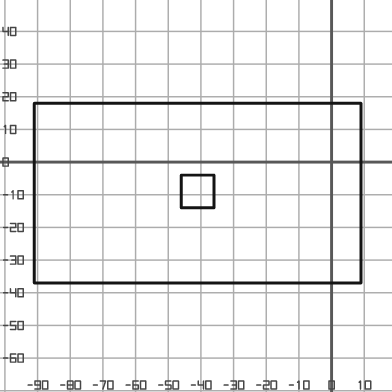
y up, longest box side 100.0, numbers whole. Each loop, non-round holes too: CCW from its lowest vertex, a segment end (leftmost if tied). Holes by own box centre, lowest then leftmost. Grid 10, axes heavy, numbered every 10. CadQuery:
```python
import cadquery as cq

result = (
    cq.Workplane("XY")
    .moveTo(-91.0, -37.0)
    .lineTo(9.0, -37.0)
    .lineTo(9.0, 18.0)
    .lineTo(-91.0, 18.0)
    .close()
    .moveTo(-46.0, -14.0)
    .lineTo(-36.0, -14.0)
    .lineTo(-36.0, -4.0)
    .lineTo(-46.0, -4.0)
    .close()
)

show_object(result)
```